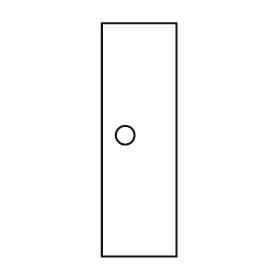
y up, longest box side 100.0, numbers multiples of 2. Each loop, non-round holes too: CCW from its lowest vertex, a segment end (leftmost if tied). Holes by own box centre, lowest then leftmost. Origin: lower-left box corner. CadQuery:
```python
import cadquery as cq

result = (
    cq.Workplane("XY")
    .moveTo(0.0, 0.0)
    .lineTo(32.0, 0.0)
    .lineTo(32.0, 100.0)
    .lineTo(0.0, 100.0)
    .close()
    .moveTo(10.0, 52.0)
    .circle(4.0)
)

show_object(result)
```